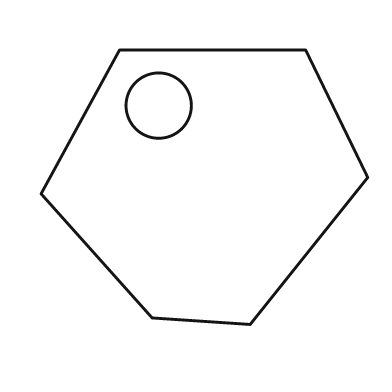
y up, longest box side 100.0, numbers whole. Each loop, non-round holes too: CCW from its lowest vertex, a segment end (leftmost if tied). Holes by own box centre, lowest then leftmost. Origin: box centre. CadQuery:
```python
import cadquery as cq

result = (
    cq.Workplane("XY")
    .moveTo(14.0, -42.0)
    .lineTo(50.0, 3.0)
    .lineTo(31.0, 42.0)
    .lineTo(-26.0, 42.0)
    .lineTo(-50.0, -2.0)
    .lineTo(-16.0, -40.0)
    .close()
    .moveTo(-14.0, 25.0)
    .circle(10.0)
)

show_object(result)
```